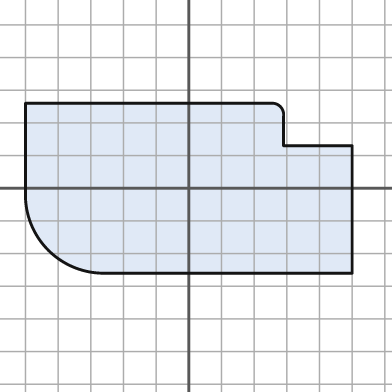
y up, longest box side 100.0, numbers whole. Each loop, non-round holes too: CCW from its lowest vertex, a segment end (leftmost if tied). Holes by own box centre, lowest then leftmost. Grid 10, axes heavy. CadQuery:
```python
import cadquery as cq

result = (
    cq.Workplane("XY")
    .moveTo(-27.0, -26.0)
    .lineTo(50.0, -26.0)
    .lineTo(50.0, 13.0)
    .lineTo(29.0, 13.0)
    .lineTo(29.0, 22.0)
    .threePointArc((28.0, 25.0), (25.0, 26.0))
    .lineTo(-50.0, 26.0)
    .lineTo(-50.0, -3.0)
    .threePointArc((-43.0, -19.0), (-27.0, -26.0))
    .close()
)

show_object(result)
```